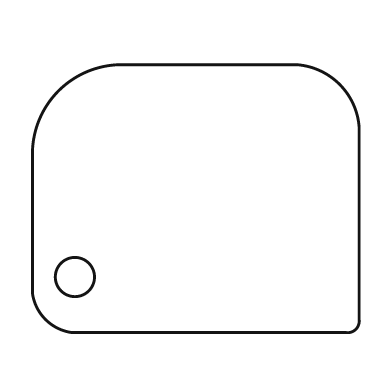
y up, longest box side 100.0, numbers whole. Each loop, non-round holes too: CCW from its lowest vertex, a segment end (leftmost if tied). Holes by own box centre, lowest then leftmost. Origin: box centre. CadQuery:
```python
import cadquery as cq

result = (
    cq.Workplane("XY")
    .moveTo(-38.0, -41.0)
    .lineTo(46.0, -41.0)
    .threePointArc((49.0, -40.0), (50.0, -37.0))
    .lineTo(50.0, 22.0)
    .threePointArc((44.0, 35.0), (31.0, 41.0))
    .lineTo(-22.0, 41.0)
    .threePointArc((-42.0, 33.0), (-50.0, 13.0))
    .lineTo(-50.0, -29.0)
    .threePointArc((-46.0, -37.0), (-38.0, -41.0))
    .close()
    .moveTo(-37.0, -24.0)
    .circle(6.0)
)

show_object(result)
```